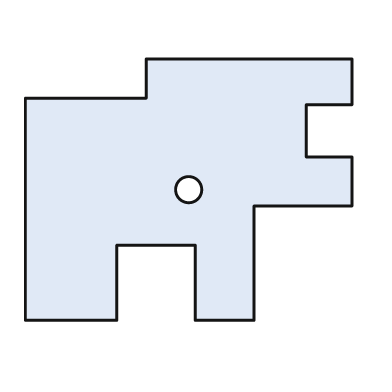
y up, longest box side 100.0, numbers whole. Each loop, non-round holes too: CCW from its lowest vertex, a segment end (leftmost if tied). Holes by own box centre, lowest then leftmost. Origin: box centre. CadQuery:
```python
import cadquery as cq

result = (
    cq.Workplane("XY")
    .moveTo(-50.0, -40.0)
    .lineTo(-22.0, -40.0)
    .lineTo(-22.0, -17.0)
    .lineTo(2.0, -17.0)
    .lineTo(2.0, -40.0)
    .lineTo(20.0, -40.0)
    .lineTo(20.0, -5.0)
    .lineTo(50.0, -5.0)
    .lineTo(50.0, 10.0)
    .lineTo(36.0, 10.0)
    .lineTo(36.0, 26.0)
    .lineTo(50.0, 26.0)
    .lineTo(50.0, 40.0)
    .lineTo(-13.0, 40.0)
    .lineTo(-13.0, 28.0)
    .lineTo(-50.0, 28.0)
    .close()
    .moveTo(0.0, 0.0)
    .circle(4.0)
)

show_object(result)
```